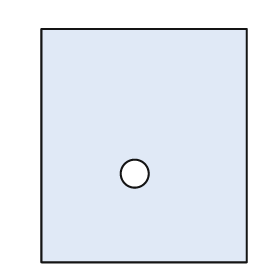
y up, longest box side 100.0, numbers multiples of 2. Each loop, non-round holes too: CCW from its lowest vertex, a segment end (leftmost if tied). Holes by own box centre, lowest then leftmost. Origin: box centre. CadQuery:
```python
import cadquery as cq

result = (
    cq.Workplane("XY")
    .moveTo(-44.0, -50.0)
    .lineTo(44.0, -50.0)
    .lineTo(44.0, 50.0)
    .lineTo(-44.0, 50.0)
    .close()
    .moveTo(-4.0, -12.0)
    .circle(6.0)
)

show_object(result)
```